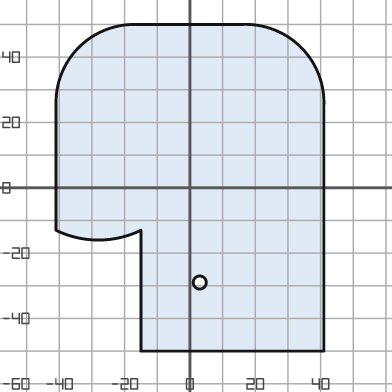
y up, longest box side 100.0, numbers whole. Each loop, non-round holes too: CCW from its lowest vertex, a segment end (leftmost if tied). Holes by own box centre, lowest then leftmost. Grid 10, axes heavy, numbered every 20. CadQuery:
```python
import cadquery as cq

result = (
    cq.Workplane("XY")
    .moveTo(-15.0, -50.0)
    .lineTo(41.0, -50.0)
    .lineTo(41.0, 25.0)
    .threePointArc((34.0, 43.0), (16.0, 50.0))
    .lineTo(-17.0, 50.0)
    .threePointArc((-34.0, 43.0), (-41.0, 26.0))
    .lineTo(-41.0, -13.0)
    .threePointArc((-28.0, -16.0), (-15.0, -13.0))
    .close()
    .moveTo(3.0, -29.0)
    .circle(2.0)
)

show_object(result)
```